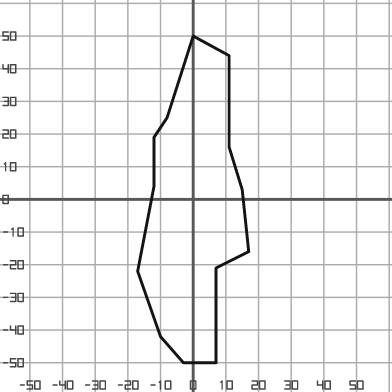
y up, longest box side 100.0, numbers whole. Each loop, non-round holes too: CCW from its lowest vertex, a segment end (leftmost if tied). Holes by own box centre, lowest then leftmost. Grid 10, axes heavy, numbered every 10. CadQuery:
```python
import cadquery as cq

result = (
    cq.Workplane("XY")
    .moveTo(-3.0, -50.0)
    .lineTo(7.0, -50.0)
    .lineTo(7.0, -21.0)
    .lineTo(17.0, -16.0)
    .lineTo(15.0, 3.0)
    .lineTo(11.0, 16.0)
    .lineTo(11.0, 44.0)
    .lineTo(0.0, 50.0)
    .lineTo(-8.0, 25.0)
    .lineTo(-12.0, 19.0)
    .lineTo(-12.0, 4.0)
    .lineTo(-17.0, -22.0)
    .lineTo(-10.0, -42.0)
    .close()
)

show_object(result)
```